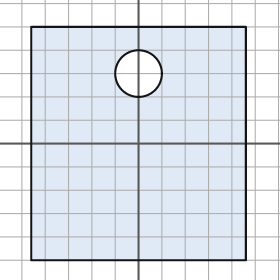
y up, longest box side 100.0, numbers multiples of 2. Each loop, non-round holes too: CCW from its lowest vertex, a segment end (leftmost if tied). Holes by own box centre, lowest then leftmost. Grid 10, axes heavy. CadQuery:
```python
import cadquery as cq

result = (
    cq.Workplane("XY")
    .moveTo(-46.0, -50.0)
    .lineTo(46.0, -50.0)
    .lineTo(46.0, 50.0)
    .lineTo(-46.0, 50.0)
    .close()
    .moveTo(0.0, 30.0)
    .circle(10.0)
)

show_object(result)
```